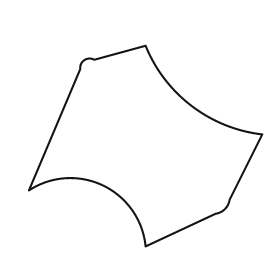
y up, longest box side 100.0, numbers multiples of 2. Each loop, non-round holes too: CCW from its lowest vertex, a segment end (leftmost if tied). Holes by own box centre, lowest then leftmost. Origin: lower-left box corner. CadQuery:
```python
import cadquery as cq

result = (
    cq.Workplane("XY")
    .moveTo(50.0, 0.0)
    .lineTo(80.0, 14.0)
    .threePointArc((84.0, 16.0), (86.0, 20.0))
    .lineTo(100.0, 48.0)
    .threePointArc((70.0, 60.0), (50.0, 86.0))
    .lineTo(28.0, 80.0)
    .threePointArc((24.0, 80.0), (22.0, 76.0))
    .lineTo(0.0, 24.0)
    .threePointArc((32.0, 26.0), (50.0, 0.0))
    .close()
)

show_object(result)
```